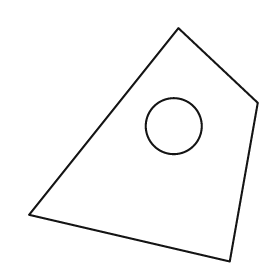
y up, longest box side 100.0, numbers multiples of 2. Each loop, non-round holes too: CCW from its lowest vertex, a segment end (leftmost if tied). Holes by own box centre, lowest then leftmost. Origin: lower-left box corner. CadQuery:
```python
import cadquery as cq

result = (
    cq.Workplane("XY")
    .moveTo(86.0, 0.0)
    .lineTo(98.0, 68.0)
    .lineTo(64.0, 100.0)
    .lineTo(0.0, 20.0)
    .close()
    .moveTo(62.0, 58.0)
    .circle(12.0)
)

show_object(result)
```